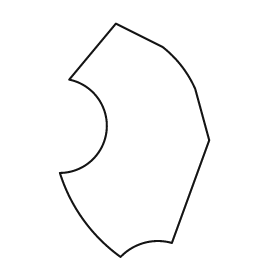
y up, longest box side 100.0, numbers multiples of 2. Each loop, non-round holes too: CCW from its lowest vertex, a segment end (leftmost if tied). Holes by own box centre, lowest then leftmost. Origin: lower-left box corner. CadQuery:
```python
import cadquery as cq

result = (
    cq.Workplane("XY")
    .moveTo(26.0, 0.0)
    .threePointArc((36.0, 6.0), (48.0, 6.0))
    .lineTo(64.0, 50.0)
    .lineTo(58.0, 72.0)
    .threePointArc((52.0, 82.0), (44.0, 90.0))
    .lineTo(24.0, 100.0)
    .lineTo(4.0, 76.0)
    .threePointArc((20.0, 54.0), (0.0, 36.0))
    .threePointArc((10.0, 16.0), (26.0, 0.0))
    .close()
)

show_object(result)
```